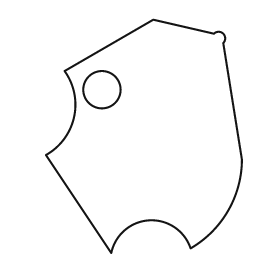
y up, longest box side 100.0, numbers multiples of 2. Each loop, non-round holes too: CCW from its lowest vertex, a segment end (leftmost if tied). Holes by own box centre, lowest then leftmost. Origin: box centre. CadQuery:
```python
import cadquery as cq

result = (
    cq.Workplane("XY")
    .moveTo(-14.0, -50.0)
    .threePointArc((2.0, -36.0), (20.0, -48.0))
    .threePointArc((36.0, -32.0), (42.0, -10.0))
    .lineTo(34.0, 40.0)
    .threePointArc((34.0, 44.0), (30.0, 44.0))
    .lineTo(4.0, 50.0)
    .lineTo(-34.0, 28.0)
    .threePointArc((-30.0, 8.0), (-42.0, -8.0))
    .close()
    .moveTo(-18.0, 20.0)
    .circle(8.0)
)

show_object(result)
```